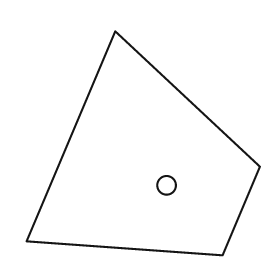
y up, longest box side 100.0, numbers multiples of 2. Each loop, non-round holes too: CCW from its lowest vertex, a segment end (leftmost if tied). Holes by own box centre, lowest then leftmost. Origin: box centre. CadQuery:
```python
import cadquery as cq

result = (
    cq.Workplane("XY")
    .moveTo(34.0, -48.0)
    .lineTo(50.0, -10.0)
    .lineTo(-12.0, 48.0)
    .lineTo(-50.0, -42.0)
    .close()
    .moveTo(10.0, -18.0)
    .circle(4.0)
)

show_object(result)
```